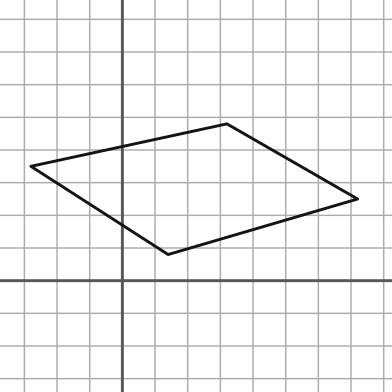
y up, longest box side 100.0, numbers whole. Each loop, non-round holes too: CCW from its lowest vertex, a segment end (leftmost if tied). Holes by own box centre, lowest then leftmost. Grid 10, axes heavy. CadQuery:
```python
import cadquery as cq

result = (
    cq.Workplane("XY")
    .moveTo(14.0, 8.0)
    .lineTo(72.0, 25.0)
    .lineTo(32.0, 48.0)
    .lineTo(-28.0, 35.0)
    .close()
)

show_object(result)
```